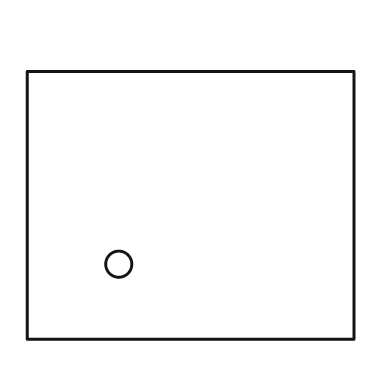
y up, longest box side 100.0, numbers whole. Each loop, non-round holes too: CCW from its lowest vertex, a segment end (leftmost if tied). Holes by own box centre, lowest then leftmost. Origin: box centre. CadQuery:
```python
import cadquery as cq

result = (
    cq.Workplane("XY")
    .moveTo(-50.0, -41.0)
    .lineTo(50.0, -41.0)
    .lineTo(50.0, 41.0)
    .lineTo(-50.0, 41.0)
    .close()
    .moveTo(-22.0, -18.0)
    .circle(4.0)
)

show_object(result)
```